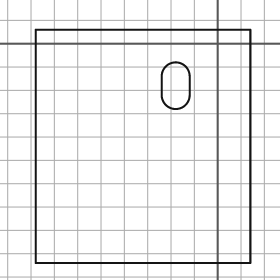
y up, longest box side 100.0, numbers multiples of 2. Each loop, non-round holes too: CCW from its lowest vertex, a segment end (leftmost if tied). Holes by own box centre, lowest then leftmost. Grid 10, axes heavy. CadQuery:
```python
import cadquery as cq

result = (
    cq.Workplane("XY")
    .moveTo(-78.0, -94.0)
    .lineTo(14.0, -94.0)
    .lineTo(14.0, 6.0)
    .lineTo(-78.0, 6.0)
    .close()
    .moveTo(-24.0, -22.0)
    .threePointArc((-18.0, -28.0), (-12.0, -22.0))
    .lineTo(-12.0, -14.0)
    .threePointArc((-18.0, -8.0), (-24.0, -14.0))
    .close()
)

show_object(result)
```